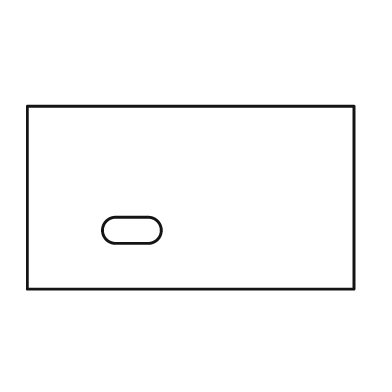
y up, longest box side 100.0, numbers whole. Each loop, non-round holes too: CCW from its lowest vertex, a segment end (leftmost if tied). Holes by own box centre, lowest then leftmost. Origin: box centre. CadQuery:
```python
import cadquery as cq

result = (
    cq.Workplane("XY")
    .moveTo(-50.0, -28.0)
    .lineTo(50.0, -28.0)
    .lineTo(50.0, 28.0)
    .lineTo(-50.0, 28.0)
    .close()
    .moveTo(-23.0, -14.0)
    .lineTo(-13.0, -14.0)
    .threePointArc((-9.0, -10.0), (-13.0, -6.0))
    .lineTo(-23.0, -6.0)
    .threePointArc((-27.0, -10.0), (-23.0, -14.0))
    .close()
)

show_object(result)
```